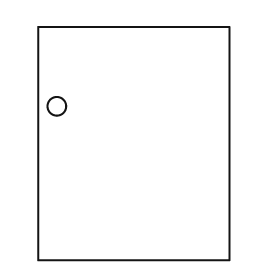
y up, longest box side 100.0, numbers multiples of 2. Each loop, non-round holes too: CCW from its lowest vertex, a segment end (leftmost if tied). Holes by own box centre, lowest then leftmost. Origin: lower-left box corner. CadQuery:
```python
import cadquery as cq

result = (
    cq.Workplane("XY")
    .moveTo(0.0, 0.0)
    .lineTo(82.0, 0.0)
    .lineTo(82.0, 100.0)
    .lineTo(0.0, 100.0)
    .close()
    .moveTo(8.0, 66.0)
    .circle(4.0)
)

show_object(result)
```